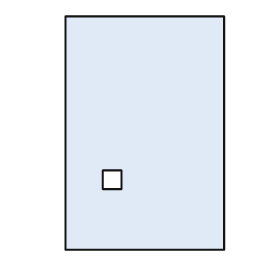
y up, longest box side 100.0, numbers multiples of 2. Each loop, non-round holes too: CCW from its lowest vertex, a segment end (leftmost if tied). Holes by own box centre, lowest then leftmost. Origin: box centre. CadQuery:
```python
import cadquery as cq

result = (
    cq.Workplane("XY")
    .moveTo(-34.0, -50.0)
    .lineTo(34.0, -50.0)
    .lineTo(34.0, 50.0)
    .lineTo(-34.0, 50.0)
    .close()
    .moveTo(-18.0, -24.0)
    .lineTo(-10.0, -24.0)
    .lineTo(-10.0, -16.0)
    .lineTo(-18.0, -16.0)
    .close()
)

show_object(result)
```